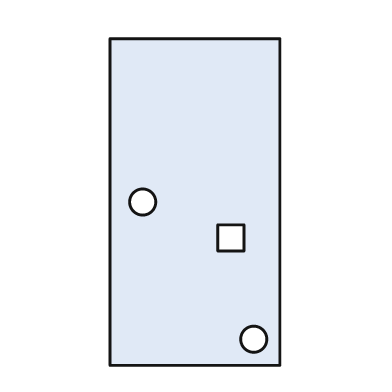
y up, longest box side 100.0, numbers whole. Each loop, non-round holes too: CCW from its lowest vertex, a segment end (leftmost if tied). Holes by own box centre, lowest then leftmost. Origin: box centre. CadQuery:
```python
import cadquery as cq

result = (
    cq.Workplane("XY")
    .moveTo(-26.0, -50.0)
    .lineTo(26.0, -50.0)
    .lineTo(26.0, 50.0)
    .lineTo(-26.0, 50.0)
    .close()
    .moveTo(18.0, -42.0)
    .circle(4.0)
    .moveTo(7.0, -15.0)
    .lineTo(15.0, -15.0)
    .lineTo(15.0, -7.0)
    .lineTo(7.0, -7.0)
    .close()
    .moveTo(-16.0, 0.0)
    .circle(4.0)
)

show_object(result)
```